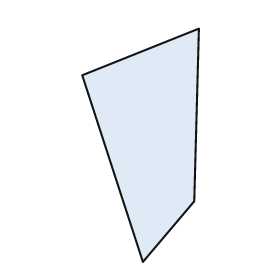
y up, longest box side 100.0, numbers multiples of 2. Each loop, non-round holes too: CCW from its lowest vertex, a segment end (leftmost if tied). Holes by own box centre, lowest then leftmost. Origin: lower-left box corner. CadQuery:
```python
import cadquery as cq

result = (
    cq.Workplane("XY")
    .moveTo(26.0, 0.0)
    .lineTo(48.0, 26.0)
    .lineTo(50.0, 100.0)
    .lineTo(0.0, 80.0)
    .close()
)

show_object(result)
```